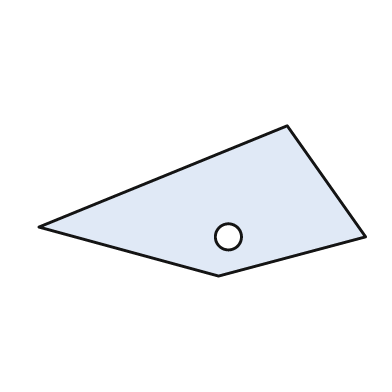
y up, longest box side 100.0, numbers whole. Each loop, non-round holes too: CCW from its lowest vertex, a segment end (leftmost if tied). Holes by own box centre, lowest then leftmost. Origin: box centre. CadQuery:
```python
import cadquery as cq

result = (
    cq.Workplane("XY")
    .moveTo(5.0, -23.0)
    .lineTo(50.0, -11.0)
    .lineTo(26.0, 23.0)
    .lineTo(-50.0, -8.0)
    .close()
    .moveTo(8.0, -11.0)
    .circle(4.0)
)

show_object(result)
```